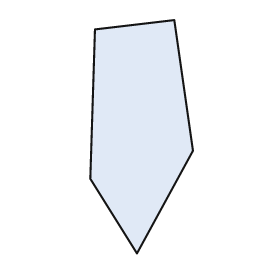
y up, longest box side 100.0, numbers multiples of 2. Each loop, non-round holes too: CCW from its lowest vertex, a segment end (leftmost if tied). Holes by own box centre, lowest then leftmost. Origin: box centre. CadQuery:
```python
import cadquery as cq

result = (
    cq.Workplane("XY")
    .moveTo(-2.0, -50.0)
    .lineTo(22.0, -6.0)
    .lineTo(14.0, 50.0)
    .lineTo(-20.0, 46.0)
    .lineTo(-22.0, -18.0)
    .close()
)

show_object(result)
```